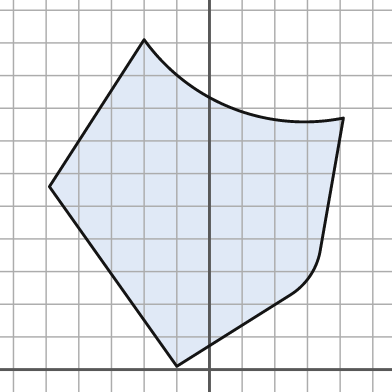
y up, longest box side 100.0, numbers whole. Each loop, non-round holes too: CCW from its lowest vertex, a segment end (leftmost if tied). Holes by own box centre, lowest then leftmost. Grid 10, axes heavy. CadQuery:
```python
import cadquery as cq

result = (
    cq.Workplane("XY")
    .moveTo(-10.0, 1.0)
    .lineTo(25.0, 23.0)
    .threePointArc((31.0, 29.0), (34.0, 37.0))
    .lineTo(41.0, 77.0)
    .threePointArc((7.0, 80.0), (-20.0, 101.0))
    .lineTo(-49.0, 56.0)
    .close()
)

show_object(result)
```